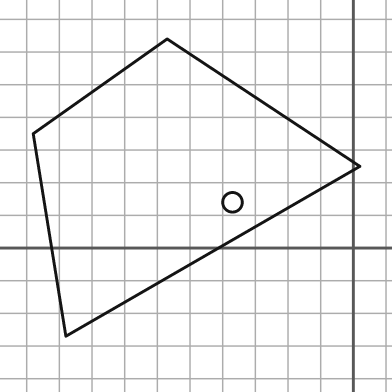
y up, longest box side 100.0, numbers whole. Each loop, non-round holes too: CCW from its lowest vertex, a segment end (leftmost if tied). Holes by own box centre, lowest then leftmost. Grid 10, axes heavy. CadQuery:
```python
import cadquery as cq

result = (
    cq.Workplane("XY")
    .moveTo(-88.0, -27.0)
    .lineTo(2.0, 25.0)
    .lineTo(-57.0, 64.0)
    .lineTo(-98.0, 35.0)
    .close()
    .moveTo(-37.0, 14.0)
    .circle(3.0)
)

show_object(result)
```